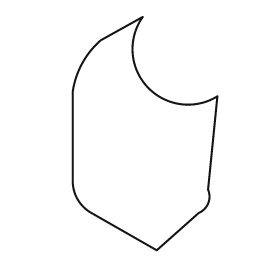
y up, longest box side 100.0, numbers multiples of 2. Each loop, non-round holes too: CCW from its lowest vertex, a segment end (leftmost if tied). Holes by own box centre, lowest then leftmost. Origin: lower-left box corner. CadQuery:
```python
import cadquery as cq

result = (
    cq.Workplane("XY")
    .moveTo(36.0, 0.0)
    .lineTo(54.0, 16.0)
    .threePointArc((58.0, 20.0), (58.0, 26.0))
    .lineTo(62.0, 66.0)
    .threePointArc((32.0, 70.0), (30.0, 100.0))
    .lineTo(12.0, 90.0)
    .threePointArc((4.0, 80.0), (0.0, 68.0))
    .lineTo(0.0, 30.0)
    .threePointArc((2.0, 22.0), (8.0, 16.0))
    .close()
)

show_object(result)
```